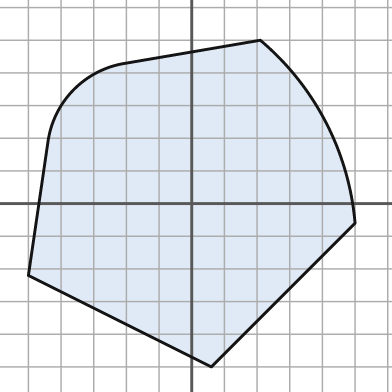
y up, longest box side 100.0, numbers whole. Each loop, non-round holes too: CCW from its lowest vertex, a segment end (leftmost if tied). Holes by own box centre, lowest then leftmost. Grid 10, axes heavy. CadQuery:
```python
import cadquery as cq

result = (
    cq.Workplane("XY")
    .moveTo(6.0, -50.0)
    .lineTo(50.0, -6.0)
    .threePointArc((41.0, 25.0), (21.0, 50.0))
    .lineTo(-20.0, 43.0)
    .threePointArc((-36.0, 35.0), (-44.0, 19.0))
    .lineTo(-50.0, -22.0)
    .close()
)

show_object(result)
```